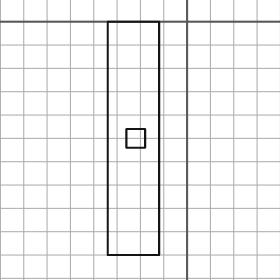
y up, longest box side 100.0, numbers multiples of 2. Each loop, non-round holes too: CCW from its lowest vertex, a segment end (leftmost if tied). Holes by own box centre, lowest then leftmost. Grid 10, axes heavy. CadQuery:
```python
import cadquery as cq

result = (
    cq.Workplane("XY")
    .moveTo(-34.0, -100.0)
    .lineTo(-12.0, -100.0)
    .lineTo(-12.0, 0.0)
    .lineTo(-34.0, 0.0)
    .close()
    .moveTo(-26.0, -54.0)
    .lineTo(-18.0, -54.0)
    .lineTo(-18.0, -46.0)
    .lineTo(-26.0, -46.0)
    .close()
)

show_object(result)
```